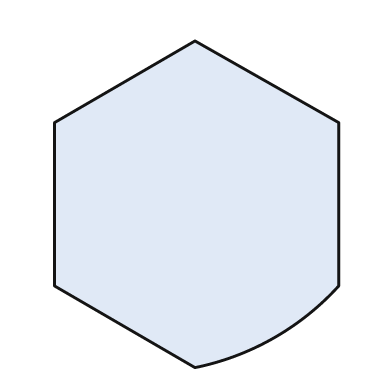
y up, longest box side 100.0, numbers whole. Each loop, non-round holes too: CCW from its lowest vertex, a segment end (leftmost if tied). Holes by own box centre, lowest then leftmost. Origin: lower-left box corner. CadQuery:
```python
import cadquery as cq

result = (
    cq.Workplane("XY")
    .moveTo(43.0, 0.0)
    .threePointArc((67.0, 9.0), (87.0, 25.0))
    .lineTo(87.0, 75.0)
    .lineTo(43.0, 100.0)
    .lineTo(0.0, 75.0)
    .lineTo(0.0, 25.0)
    .close()
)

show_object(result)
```